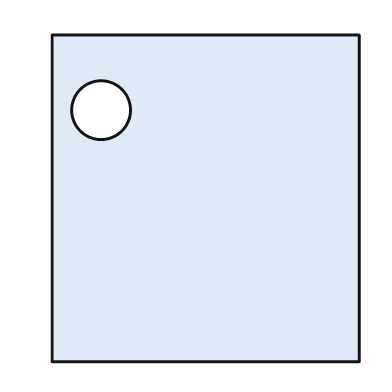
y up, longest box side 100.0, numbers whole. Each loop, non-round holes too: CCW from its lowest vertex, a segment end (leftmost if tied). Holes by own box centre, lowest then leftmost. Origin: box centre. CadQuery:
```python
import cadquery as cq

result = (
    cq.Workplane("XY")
    .moveTo(-47.0, -50.0)
    .lineTo(47.0, -50.0)
    .lineTo(47.0, 50.0)
    .lineTo(-47.0, 50.0)
    .close()
    .moveTo(-32.0, 27.0)
    .circle(9.0)
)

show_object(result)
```